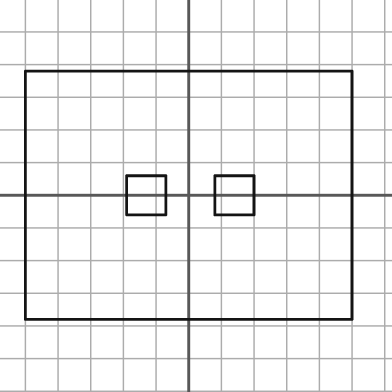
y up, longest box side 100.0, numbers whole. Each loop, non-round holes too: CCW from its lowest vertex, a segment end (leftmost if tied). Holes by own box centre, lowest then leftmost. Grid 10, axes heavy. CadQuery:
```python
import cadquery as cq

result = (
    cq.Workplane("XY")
    .moveTo(-50.0, -38.0)
    .lineTo(50.0, -38.0)
    .lineTo(50.0, 38.0)
    .lineTo(-50.0, 38.0)
    .close()
    .moveTo(-19.0, -6.0)
    .lineTo(-7.0, -6.0)
    .lineTo(-7.0, 6.0)
    .lineTo(-19.0, 6.0)
    .close()
    .moveTo(8.0, -6.0)
    .lineTo(20.0, -6.0)
    .lineTo(20.0, 6.0)
    .lineTo(8.0, 6.0)
    .close()
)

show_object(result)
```